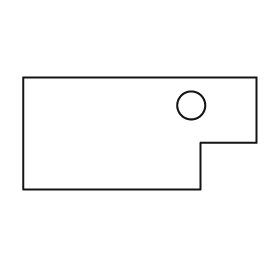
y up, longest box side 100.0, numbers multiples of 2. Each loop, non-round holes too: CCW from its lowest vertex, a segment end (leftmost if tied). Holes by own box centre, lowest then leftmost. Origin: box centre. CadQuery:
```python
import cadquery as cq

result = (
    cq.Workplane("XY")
    .moveTo(-50.0, -24.0)
    .lineTo(26.0, -24.0)
    .lineTo(26.0, -4.0)
    .lineTo(50.0, -4.0)
    .lineTo(50.0, 24.0)
    .lineTo(-50.0, 24.0)
    .close()
    .moveTo(22.0, 12.0)
    .circle(6.0)
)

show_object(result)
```